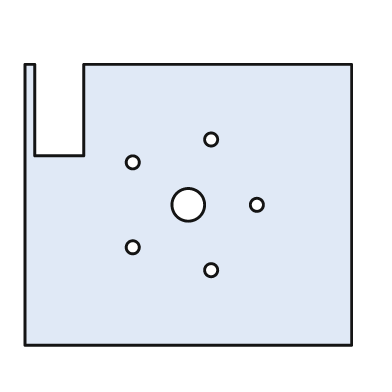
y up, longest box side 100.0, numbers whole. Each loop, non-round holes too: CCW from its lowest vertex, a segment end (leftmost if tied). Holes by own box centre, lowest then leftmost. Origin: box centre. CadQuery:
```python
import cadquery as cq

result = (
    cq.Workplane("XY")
    .moveTo(-50.0, -43.0)
    .lineTo(50.0, -43.0)
    .lineTo(50.0, 43.0)
    .lineTo(-32.0, 43.0)
    .lineTo(-32.0, 15.0)
    .lineTo(-47.0, 15.0)
    .lineTo(-47.0, 43.0)
    .lineTo(-50.0, 43.0)
    .close()
    .moveTo(7.0, -20.0)
    .circle(2.0)
    .moveTo(-17.0, -13.0)
    .circle(2.0)
    .moveTo(0.0, 0.0)
    .circle(5.0)
    .moveTo(21.0, 0.0)
    .circle(2.0)
    .moveTo(-17.0, 13.0)
    .circle(2.0)
    .moveTo(7.0, 20.0)
    .circle(2.0)
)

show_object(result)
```